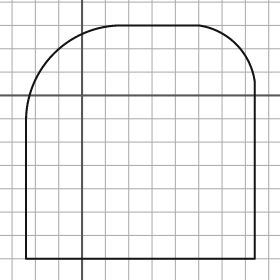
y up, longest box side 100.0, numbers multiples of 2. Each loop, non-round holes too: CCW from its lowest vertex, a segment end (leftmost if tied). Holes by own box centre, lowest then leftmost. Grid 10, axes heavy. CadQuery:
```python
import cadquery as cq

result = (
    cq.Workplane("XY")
    .moveTo(-24.0, -70.0)
    .lineTo(74.0, -70.0)
    .lineTo(74.0, 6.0)
    .threePointArc((66.0, 22.0), (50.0, 30.0))
    .lineTo(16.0, 30.0)
    .threePointArc((-12.0, 18.0), (-24.0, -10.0))
    .close()
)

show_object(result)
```